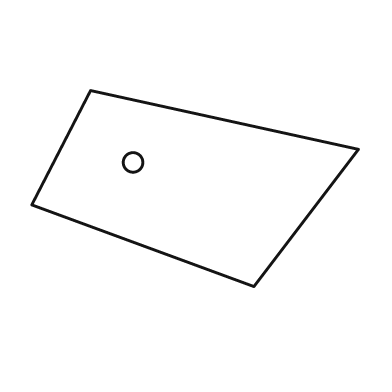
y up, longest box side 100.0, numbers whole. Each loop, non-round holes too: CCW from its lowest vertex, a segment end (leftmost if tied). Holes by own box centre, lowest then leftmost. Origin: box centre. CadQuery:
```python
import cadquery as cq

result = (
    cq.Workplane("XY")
    .moveTo(18.0, -30.0)
    .lineTo(50.0, 12.0)
    .lineTo(-32.0, 30.0)
    .lineTo(-50.0, -5.0)
    .close()
    .moveTo(-19.0, 8.0)
    .circle(3.0)
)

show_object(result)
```